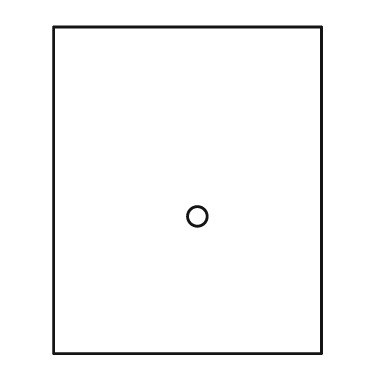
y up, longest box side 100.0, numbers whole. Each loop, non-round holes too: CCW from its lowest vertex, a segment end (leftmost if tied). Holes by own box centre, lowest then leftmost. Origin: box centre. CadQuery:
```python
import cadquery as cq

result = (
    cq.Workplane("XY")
    .moveTo(-41.0, -50.0)
    .lineTo(41.0, -50.0)
    .lineTo(41.0, 50.0)
    .lineTo(-41.0, 50.0)
    .close()
    .moveTo(3.0, -8.0)
    .circle(3.0)
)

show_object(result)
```